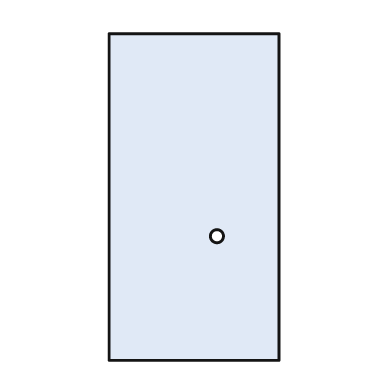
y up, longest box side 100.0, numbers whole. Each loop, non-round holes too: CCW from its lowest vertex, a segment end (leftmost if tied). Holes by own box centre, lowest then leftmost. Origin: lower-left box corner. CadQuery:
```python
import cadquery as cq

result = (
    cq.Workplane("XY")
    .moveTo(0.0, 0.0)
    .lineTo(52.0, 0.0)
    .lineTo(52.0, 100.0)
    .lineTo(0.0, 100.0)
    .close()
    .moveTo(33.0, 38.0)
    .circle(2.0)
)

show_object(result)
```